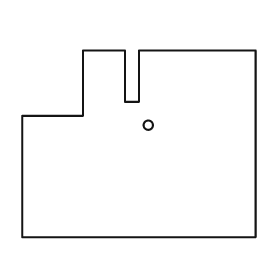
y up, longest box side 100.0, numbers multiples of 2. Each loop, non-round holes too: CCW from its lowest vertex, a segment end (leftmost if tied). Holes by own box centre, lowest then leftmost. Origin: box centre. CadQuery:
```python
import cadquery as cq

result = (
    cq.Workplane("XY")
    .moveTo(-50.0, -40.0)
    .lineTo(50.0, -40.0)
    .lineTo(50.0, 40.0)
    .lineTo(0.0, 40.0)
    .lineTo(0.0, 18.0)
    .lineTo(-6.0, 18.0)
    .lineTo(-6.0, 40.0)
    .lineTo(-24.0, 40.0)
    .lineTo(-24.0, 12.0)
    .lineTo(-50.0, 12.0)
    .close()
    .moveTo(4.0, 8.0)
    .circle(2.0)
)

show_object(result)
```